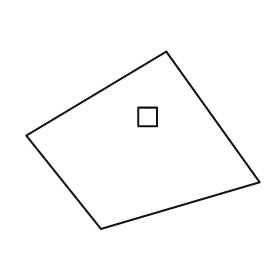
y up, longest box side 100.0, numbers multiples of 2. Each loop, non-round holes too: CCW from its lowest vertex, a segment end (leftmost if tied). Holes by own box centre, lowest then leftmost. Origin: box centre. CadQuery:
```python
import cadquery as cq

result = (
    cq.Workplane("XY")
    .moveTo(-18.0, -38.0)
    .lineTo(50.0, -18.0)
    .lineTo(10.0, 38.0)
    .lineTo(-50.0, 2.0)
    .close()
    .moveTo(-2.0, 6.0)
    .lineTo(6.0, 6.0)
    .lineTo(6.0, 14.0)
    .lineTo(-2.0, 14.0)
    .close()
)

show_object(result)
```